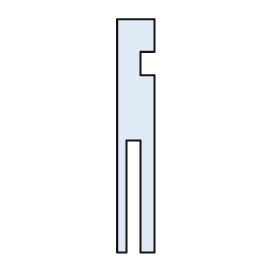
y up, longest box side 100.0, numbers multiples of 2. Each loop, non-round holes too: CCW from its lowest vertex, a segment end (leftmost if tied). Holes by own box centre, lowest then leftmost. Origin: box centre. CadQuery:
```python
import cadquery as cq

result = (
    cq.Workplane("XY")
    .moveTo(-8.0, -50.0)
    .lineTo(-4.0, -50.0)
    .lineTo(-4.0, -2.0)
    .lineTo(2.0, -2.0)
    .lineTo(2.0, -50.0)
    .lineTo(8.0, -50.0)
    .lineTo(8.0, 26.0)
    .lineTo(2.0, 26.0)
    .lineTo(2.0, 36.0)
    .lineTo(8.0, 36.0)
    .lineTo(8.0, 50.0)
    .lineTo(-8.0, 50.0)
    .close()
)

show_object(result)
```